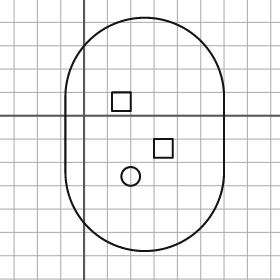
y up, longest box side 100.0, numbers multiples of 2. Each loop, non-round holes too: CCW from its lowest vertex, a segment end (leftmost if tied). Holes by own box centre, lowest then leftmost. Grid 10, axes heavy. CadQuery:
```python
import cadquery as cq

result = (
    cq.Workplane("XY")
    .moveTo(-8.0, -24.0)
    .threePointArc((26.0, -58.0), (60.0, -24.0))
    .lineTo(60.0, 8.0)
    .threePointArc((26.0, 42.0), (-8.0, 8.0))
    .close()
    .moveTo(20.0, -26.0)
    .circle(4.0)
    .moveTo(30.0, -18.0)
    .lineTo(38.0, -18.0)
    .lineTo(38.0, -10.0)
    .lineTo(30.0, -10.0)
    .close()
    .moveTo(12.0, 2.0)
    .lineTo(20.0, 2.0)
    .lineTo(20.0, 10.0)
    .lineTo(12.0, 10.0)
    .close()
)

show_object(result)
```